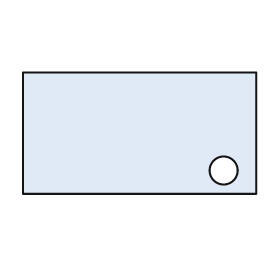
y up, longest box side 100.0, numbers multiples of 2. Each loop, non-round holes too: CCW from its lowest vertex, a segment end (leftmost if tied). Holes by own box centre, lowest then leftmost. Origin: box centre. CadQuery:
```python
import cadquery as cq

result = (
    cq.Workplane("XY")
    .moveTo(-50.0, -26.0)
    .lineTo(50.0, -26.0)
    .lineTo(50.0, 26.0)
    .lineTo(-50.0, 26.0)
    .close()
    .moveTo(36.0, -16.0)
    .circle(6.0)
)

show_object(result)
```